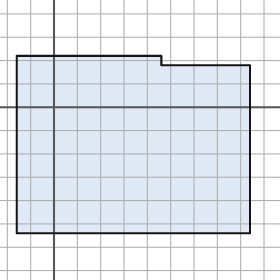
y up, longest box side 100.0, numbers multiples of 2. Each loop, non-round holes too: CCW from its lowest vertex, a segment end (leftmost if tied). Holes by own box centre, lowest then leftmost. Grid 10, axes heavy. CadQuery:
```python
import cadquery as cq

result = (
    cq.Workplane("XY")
    .moveTo(-16.0, -54.0)
    .lineTo(84.0, -54.0)
    .lineTo(84.0, 18.0)
    .lineTo(46.0, 18.0)
    .lineTo(46.0, 22.0)
    .lineTo(-16.0, 22.0)
    .close()
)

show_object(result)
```